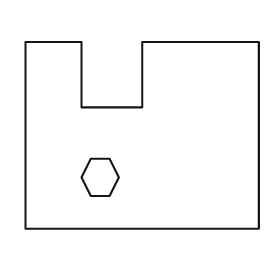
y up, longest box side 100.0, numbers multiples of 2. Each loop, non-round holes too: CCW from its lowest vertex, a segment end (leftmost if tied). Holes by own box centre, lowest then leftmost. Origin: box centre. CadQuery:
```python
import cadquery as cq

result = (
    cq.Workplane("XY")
    .moveTo(-50.0, -40.0)
    .lineTo(50.0, -40.0)
    .lineTo(50.0, 40.0)
    .lineTo(0.0, 40.0)
    .lineTo(0.0, 12.0)
    .lineTo(-26.0, 12.0)
    .lineTo(-26.0, 40.0)
    .lineTo(-50.0, 40.0)
    .close()
    .moveTo(-22.0, -26.0)
    .lineTo(-14.0, -26.0)
    .lineTo(-10.0, -18.0)
    .lineTo(-14.0, -10.0)
    .lineTo(-22.0, -10.0)
    .lineTo(-26.0, -18.0)
    .close()
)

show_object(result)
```